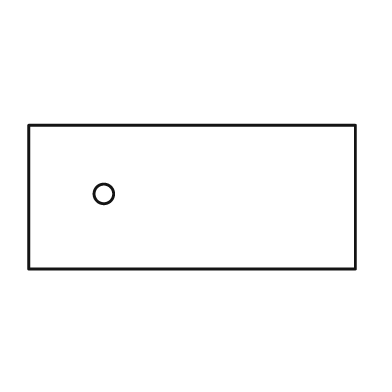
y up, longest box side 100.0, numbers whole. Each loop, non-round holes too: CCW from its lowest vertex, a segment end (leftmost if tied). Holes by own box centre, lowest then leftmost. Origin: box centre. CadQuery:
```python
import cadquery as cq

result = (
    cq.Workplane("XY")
    .moveTo(-50.0, -22.0)
    .lineTo(50.0, -22.0)
    .lineTo(50.0, 22.0)
    .lineTo(-50.0, 22.0)
    .close()
    .moveTo(-27.0, 1.0)
    .circle(3.0)
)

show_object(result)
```